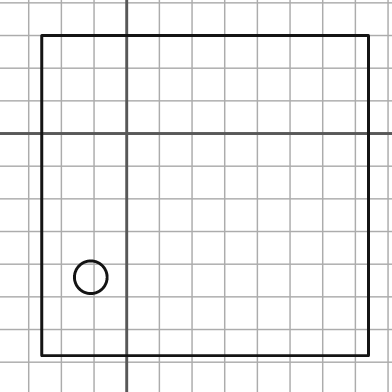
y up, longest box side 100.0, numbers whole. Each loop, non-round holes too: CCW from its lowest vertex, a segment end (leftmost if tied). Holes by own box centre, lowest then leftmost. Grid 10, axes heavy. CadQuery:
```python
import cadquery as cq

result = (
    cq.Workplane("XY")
    .moveTo(-26.0, -68.0)
    .lineTo(74.0, -68.0)
    .lineTo(74.0, 30.0)
    .lineTo(-26.0, 30.0)
    .close()
    .moveTo(-11.0, -44.0)
    .circle(5.0)
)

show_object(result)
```